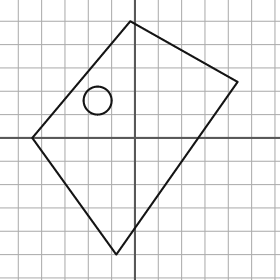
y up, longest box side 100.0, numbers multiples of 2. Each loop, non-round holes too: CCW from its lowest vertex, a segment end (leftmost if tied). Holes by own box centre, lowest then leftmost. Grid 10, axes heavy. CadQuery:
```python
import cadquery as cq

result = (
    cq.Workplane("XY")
    .moveTo(-8.0, -50.0)
    .lineTo(44.0, 24.0)
    .lineTo(-2.0, 50.0)
    .lineTo(-44.0, 0.0)
    .close()
    .moveTo(-16.0, 16.0)
    .circle(6.0)
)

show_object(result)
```